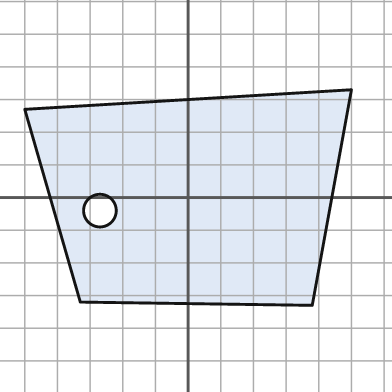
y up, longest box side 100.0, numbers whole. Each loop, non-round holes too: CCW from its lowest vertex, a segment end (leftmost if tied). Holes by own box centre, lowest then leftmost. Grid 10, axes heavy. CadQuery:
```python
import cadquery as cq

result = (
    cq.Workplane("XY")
    .moveTo(38.0, -33.0)
    .lineTo(50.0, 33.0)
    .lineTo(-50.0, 27.0)
    .lineTo(-33.0, -32.0)
    .close()
    .moveTo(-27.0, -4.0)
    .circle(5.0)
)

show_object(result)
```